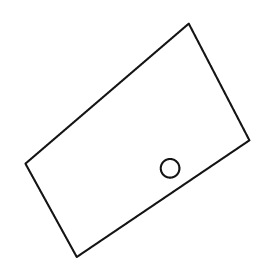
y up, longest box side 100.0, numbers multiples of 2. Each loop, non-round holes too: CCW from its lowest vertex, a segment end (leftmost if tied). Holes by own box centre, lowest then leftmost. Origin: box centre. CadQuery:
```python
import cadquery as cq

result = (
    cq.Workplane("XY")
    .moveTo(-26.0, -50.0)
    .lineTo(48.0, 0.0)
    .lineTo(22.0, 50.0)
    .lineTo(-48.0, -10.0)
    .close()
    .moveTo(14.0, -12.0)
    .circle(4.0)
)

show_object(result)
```